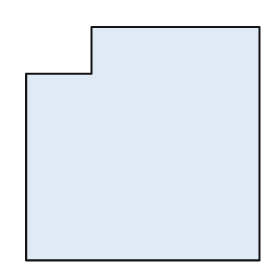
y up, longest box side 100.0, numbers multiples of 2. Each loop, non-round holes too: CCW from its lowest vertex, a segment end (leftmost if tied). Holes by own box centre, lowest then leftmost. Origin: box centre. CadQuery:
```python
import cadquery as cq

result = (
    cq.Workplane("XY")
    .moveTo(-50.0, -50.0)
    .lineTo(50.0, -50.0)
    .lineTo(50.0, 50.0)
    .lineTo(-22.0, 50.0)
    .lineTo(-22.0, 30.0)
    .lineTo(-50.0, 30.0)
    .close()
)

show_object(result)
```